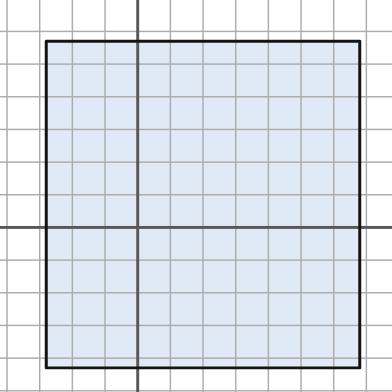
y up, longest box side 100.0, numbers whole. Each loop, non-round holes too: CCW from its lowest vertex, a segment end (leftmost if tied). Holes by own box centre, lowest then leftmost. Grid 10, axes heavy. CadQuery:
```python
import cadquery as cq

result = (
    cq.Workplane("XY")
    .moveTo(-28.0, -43.0)
    .lineTo(68.0, -43.0)
    .lineTo(68.0, 57.0)
    .lineTo(-28.0, 57.0)
    .close()
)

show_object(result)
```